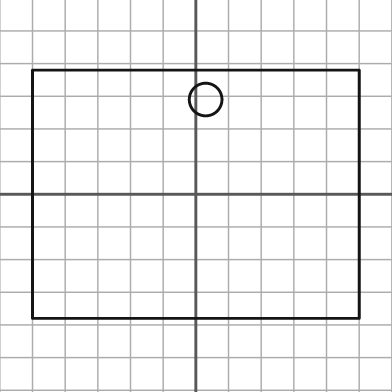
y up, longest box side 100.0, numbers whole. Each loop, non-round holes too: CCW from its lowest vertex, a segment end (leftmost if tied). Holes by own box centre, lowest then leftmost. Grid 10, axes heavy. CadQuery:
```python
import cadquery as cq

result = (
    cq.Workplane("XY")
    .moveTo(-50.0, -38.0)
    .lineTo(50.0, -38.0)
    .lineTo(50.0, 38.0)
    .lineTo(-50.0, 38.0)
    .close()
    .moveTo(3.0, 29.0)
    .circle(5.0)
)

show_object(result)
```